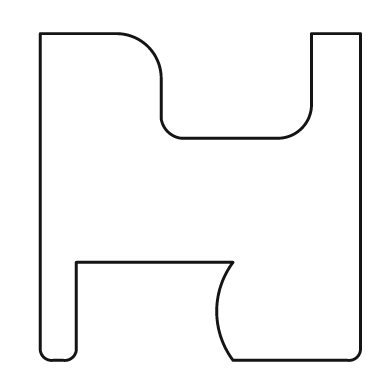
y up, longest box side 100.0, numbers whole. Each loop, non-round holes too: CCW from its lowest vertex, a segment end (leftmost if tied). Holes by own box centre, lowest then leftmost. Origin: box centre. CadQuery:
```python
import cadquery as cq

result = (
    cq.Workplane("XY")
    .moveTo(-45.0, -50.0)
    .lineTo(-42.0, -50.0)
    .threePointArc((-39.0, -49.0), (-38.0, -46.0))
    .lineTo(-38.0, -20.0)
    .lineTo(10.0, -20.0)
    .threePointArc((5.0, -35.0), (10.0, -50.0))
    .lineTo(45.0, -50.0)
    .threePointArc((48.0, -49.0), (49.0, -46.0))
    .lineTo(49.0, 50.0)
    .lineTo(34.0, 50.0)
    .lineTo(34.0, 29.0)
    .threePointArc((31.0, 21.0), (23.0, 18.0))
    .lineTo(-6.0, 18.0)
    .threePointArc((-10.0, 20.0), (-12.0, 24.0))
    .lineTo(-12.0, 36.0)
    .threePointArc((-16.0, 46.0), (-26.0, 50.0))
    .lineTo(-49.0, 50.0)
    .lineTo(-49.0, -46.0)
    .threePointArc((-48.0, -49.0), (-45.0, -50.0))
    .close()
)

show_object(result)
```